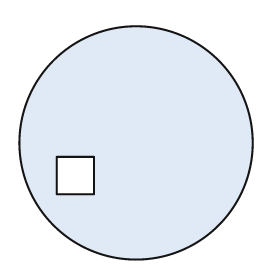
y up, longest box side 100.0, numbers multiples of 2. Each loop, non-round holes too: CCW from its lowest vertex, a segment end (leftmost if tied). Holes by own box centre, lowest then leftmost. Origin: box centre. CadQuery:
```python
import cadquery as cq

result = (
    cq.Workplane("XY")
    .moveTo(0.0, 0.0)
    .circle(50.0)
    .moveTo(-34.0, -22.0)
    .lineTo(-18.0, -22.0)
    .lineTo(-18.0, -6.0)
    .lineTo(-34.0, -6.0)
    .close()
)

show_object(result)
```